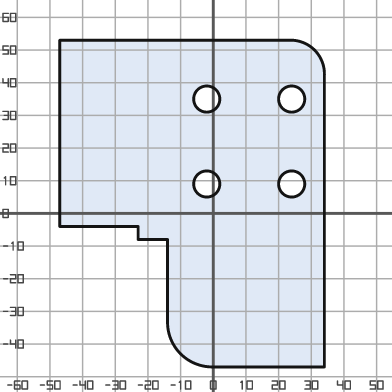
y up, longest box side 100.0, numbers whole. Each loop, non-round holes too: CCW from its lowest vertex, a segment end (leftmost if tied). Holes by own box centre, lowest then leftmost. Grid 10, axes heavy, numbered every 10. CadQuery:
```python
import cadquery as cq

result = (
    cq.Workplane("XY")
    .moveTo(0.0, -47.0)
    .lineTo(34.0, -47.0)
    .lineTo(34.0, 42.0)
    .threePointArc((31.0, 50.0), (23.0, 53.0))
    .lineTo(-47.0, 53.0)
    .lineTo(-47.0, -4.0)
    .lineTo(-23.0, -4.0)
    .lineTo(-23.0, -8.0)
    .lineTo(-14.0, -8.0)
    .lineTo(-14.0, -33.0)
    .threePointArc((-10.0, -43.0), (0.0, -47.0))
    .close()
    .moveTo(-2.0, 9.0)
    .circle(4.0)
    .moveTo(24.0, 9.0)
    .circle(4.0)
    .moveTo(-2.0, 35.0)
    .circle(4.0)
    .moveTo(24.0, 35.0)
    .circle(4.0)
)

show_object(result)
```